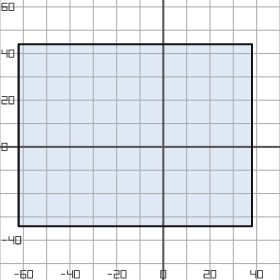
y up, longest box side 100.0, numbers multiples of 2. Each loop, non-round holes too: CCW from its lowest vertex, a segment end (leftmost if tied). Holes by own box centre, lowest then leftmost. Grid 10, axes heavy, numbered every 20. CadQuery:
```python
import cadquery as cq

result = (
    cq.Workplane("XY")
    .moveTo(-62.0, -34.0)
    .lineTo(38.0, -34.0)
    .lineTo(38.0, 44.0)
    .lineTo(-62.0, 44.0)
    .close()
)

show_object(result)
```